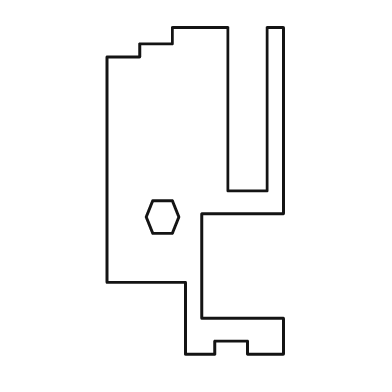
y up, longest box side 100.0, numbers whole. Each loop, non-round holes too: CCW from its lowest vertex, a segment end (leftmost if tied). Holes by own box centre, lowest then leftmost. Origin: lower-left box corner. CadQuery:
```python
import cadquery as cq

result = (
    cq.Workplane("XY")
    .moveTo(24.0, 0.0)
    .lineTo(33.0, 0.0)
    .lineTo(33.0, 4.0)
    .lineTo(43.0, 4.0)
    .lineTo(43.0, 0.0)
    .lineTo(54.0, 0.0)
    .lineTo(54.0, 11.0)
    .lineTo(29.0, 11.0)
    .lineTo(29.0, 43.0)
    .lineTo(54.0, 43.0)
    .lineTo(54.0, 100.0)
    .lineTo(49.0, 100.0)
    .lineTo(49.0, 50.0)
    .lineTo(37.0, 50.0)
    .lineTo(37.0, 100.0)
    .lineTo(20.0, 100.0)
    .lineTo(20.0, 95.0)
    .lineTo(10.0, 95.0)
    .lineTo(10.0, 91.0)
    .lineTo(0.0, 91.0)
    .lineTo(0.0, 22.0)
    .lineTo(24.0, 22.0)
    .close()
    .moveTo(14.0, 37.0)
    .lineTo(20.0, 37.0)
    .lineTo(22.0, 42.0)
    .lineTo(20.0, 47.0)
    .lineTo(14.0, 47.0)
    .lineTo(12.0, 42.0)
    .close()
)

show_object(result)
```